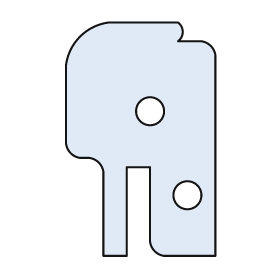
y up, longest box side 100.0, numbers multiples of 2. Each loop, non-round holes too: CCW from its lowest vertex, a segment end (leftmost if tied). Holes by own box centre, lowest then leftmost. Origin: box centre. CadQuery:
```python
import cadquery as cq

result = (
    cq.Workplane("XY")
    .moveTo(-16.0, -50.0)
    .lineTo(-6.0, -50.0)
    .lineTo(-6.0, -12.0)
    .lineTo(4.0, -12.0)
    .lineTo(4.0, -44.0)
    .threePointArc((6.0, -48.0), (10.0, -50.0))
    .lineTo(32.0, -50.0)
    .lineTo(32.0, 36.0)
    .threePointArc((30.0, 40.0), (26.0, 42.0))
    .lineTo(16.0, 42.0)
    .threePointArc((18.0, 46.0), (16.0, 50.0))
    .lineTo(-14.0, 50.0)
    .threePointArc((-26.0, 44.0), (-32.0, 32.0))
    .lineTo(-32.0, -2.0)
    .threePointArc((-30.0, -6.0), (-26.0, -8.0))
    .lineTo(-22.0, -8.0)
    .threePointArc((-18.0, -10.0), (-16.0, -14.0))
    .close()
    .moveTo(20.0, -24.0)
    .circle(6.0)
    .moveTo(4.0, 12.0)
    .circle(6.0)
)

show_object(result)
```